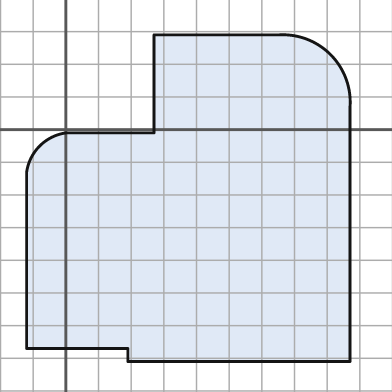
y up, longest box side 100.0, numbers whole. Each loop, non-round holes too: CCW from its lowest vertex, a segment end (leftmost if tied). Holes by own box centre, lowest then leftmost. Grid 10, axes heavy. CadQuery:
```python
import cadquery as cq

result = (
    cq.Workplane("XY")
    .moveTo(19.0, -71.0)
    .lineTo(87.0, -71.0)
    .lineTo(87.0, 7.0)
    .threePointArc((81.0, 23.0), (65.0, 29.0))
    .lineTo(27.0, 29.0)
    .lineTo(27.0, -1.0)
    .lineTo(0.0, -1.0)
    .threePointArc((-8.0, -5.0), (-12.0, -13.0))
    .lineTo(-12.0, -67.0)
    .lineTo(19.0, -67.0)
    .close()
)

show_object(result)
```